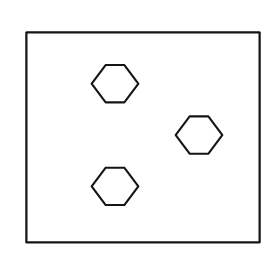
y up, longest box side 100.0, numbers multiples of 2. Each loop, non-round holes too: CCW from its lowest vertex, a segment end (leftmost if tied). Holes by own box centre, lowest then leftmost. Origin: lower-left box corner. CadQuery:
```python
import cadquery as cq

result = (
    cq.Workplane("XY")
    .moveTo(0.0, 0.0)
    .lineTo(100.0, 0.0)
    .lineTo(100.0, 90.0)
    .lineTo(0.0, 90.0)
    .close()
    .moveTo(34.0, 16.0)
    .lineTo(42.0, 16.0)
    .lineTo(48.0, 24.0)
    .lineTo(42.0, 32.0)
    .lineTo(34.0, 32.0)
    .lineTo(28.0, 24.0)
    .close()
    .moveTo(70.0, 38.0)
    .lineTo(78.0, 38.0)
    .lineTo(84.0, 46.0)
    .lineTo(78.0, 54.0)
    .lineTo(70.0, 54.0)
    .lineTo(64.0, 46.0)
    .close()
    .moveTo(34.0, 60.0)
    .lineTo(42.0, 60.0)
    .lineTo(48.0, 68.0)
    .lineTo(42.0, 76.0)
    .lineTo(34.0, 76.0)
    .lineTo(28.0, 68.0)
    .close()
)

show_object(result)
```